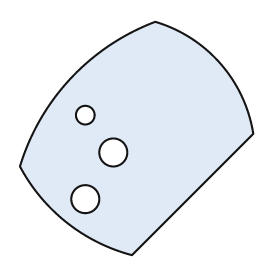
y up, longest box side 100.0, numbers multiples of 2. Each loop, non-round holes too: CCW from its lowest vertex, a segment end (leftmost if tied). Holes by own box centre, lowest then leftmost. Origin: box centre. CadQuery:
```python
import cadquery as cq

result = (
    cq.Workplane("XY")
    .moveTo(-2.0, -50.0)
    .lineTo(50.0, 2.0)
    .threePointArc((36.0, 32.0), (8.0, 50.0))
    .threePointArc((-28.0, 26.0), (-50.0, -12.0))
    .threePointArc((-30.0, -36.0), (-2.0, -50.0))
    .close()
    .moveTo(-22.0, -26.0)
    .circle(6.0)
    .moveTo(-10.0, -6.0)
    .circle(6.0)
    .moveTo(-22.0, 10.0)
    .circle(4.0)
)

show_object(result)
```